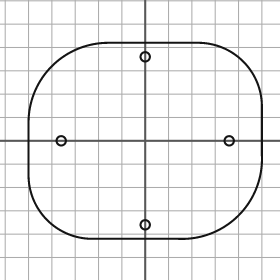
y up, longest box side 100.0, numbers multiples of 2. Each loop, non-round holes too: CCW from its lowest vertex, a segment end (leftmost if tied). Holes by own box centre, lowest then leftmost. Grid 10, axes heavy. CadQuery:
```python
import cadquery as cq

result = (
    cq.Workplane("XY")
    .moveTo(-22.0, -42.0)
    .lineTo(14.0, -42.0)
    .threePointArc((40.0, -32.0), (50.0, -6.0))
    .lineTo(50.0, 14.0)
    .threePointArc((42.0, 34.0), (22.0, 42.0))
    .lineTo(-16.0, 42.0)
    .threePointArc((-40.0, 32.0), (-50.0, 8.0))
    .lineTo(-50.0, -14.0)
    .threePointArc((-42.0, -34.0), (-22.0, -42.0))
    .close()
    .moveTo(0.0, -36.0)
    .circle(2.0)
    .moveTo(-36.0, 0.0)
    .circle(2.0)
    .moveTo(36.0, 0.0)
    .circle(2.0)
    .moveTo(0.0, 36.0)
    .circle(2.0)
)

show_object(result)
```